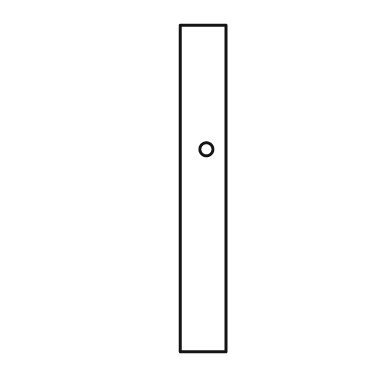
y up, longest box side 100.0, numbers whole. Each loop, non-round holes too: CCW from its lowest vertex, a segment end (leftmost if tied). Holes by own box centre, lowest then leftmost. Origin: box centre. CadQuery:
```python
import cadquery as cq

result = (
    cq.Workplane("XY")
    .moveTo(-7.0, -50.0)
    .lineTo(7.0, -50.0)
    .lineTo(7.0, 50.0)
    .lineTo(-7.0, 50.0)
    .close()
    .moveTo(1.0, 12.0)
    .circle(2.0)
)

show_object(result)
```